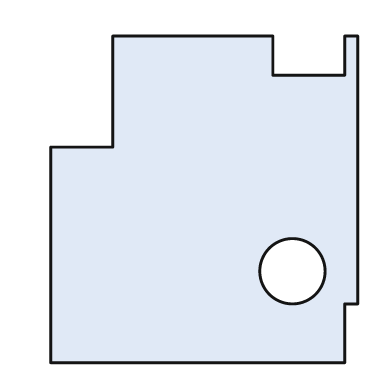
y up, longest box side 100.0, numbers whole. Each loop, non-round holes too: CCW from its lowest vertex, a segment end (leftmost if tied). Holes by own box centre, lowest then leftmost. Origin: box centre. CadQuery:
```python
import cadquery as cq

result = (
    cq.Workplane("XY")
    .moveTo(-47.0, -50.0)
    .lineTo(43.0, -50.0)
    .lineTo(43.0, -32.0)
    .lineTo(47.0, -32.0)
    .lineTo(47.0, 50.0)
    .lineTo(43.0, 50.0)
    .lineTo(43.0, 38.0)
    .lineTo(21.0, 38.0)
    .lineTo(21.0, 50.0)
    .lineTo(-28.0, 50.0)
    .lineTo(-28.0, 16.0)
    .lineTo(-47.0, 16.0)
    .close()
    .moveTo(27.0, -22.0)
    .circle(10.0)
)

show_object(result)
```